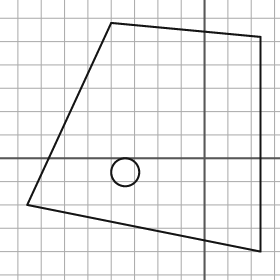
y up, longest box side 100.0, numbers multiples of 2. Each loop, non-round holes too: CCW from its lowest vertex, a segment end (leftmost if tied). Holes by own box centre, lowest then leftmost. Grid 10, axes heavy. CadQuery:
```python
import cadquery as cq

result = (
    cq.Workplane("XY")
    .moveTo(24.0, -40.0)
    .lineTo(24.0, 52.0)
    .lineTo(-40.0, 58.0)
    .lineTo(-76.0, -20.0)
    .close()
    .moveTo(-34.0, -6.0)
    .circle(6.0)
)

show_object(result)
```